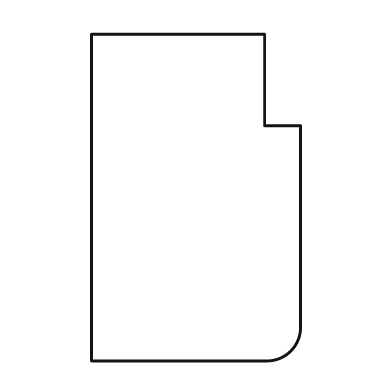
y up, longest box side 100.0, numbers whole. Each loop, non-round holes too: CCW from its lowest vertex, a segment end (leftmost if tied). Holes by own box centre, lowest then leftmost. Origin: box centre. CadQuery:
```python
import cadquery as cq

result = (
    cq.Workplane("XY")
    .moveTo(-32.0, -50.0)
    .lineTo(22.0, -50.0)
    .threePointArc((29.0, -47.0), (32.0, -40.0))
    .lineTo(32.0, 22.0)
    .lineTo(21.0, 22.0)
    .lineTo(21.0, 50.0)
    .lineTo(-32.0, 50.0)
    .close()
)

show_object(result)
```